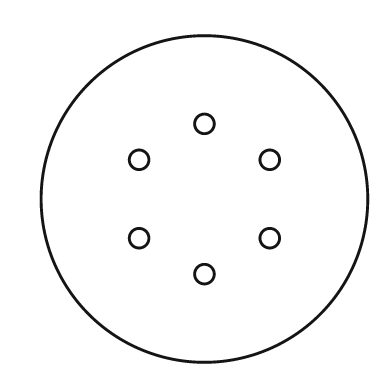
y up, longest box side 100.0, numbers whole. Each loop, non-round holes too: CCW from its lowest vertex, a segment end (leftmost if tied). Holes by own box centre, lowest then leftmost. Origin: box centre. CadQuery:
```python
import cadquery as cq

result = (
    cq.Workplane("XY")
    .moveTo(0.0, 0.0)
    .circle(50.0)
    .moveTo(0.0, -23.0)
    .circle(3.0)
    .moveTo(-20.0, -12.0)
    .circle(3.0)
    .moveTo(20.0, -12.0)
    .circle(3.0)
    .moveTo(-20.0, 12.0)
    .circle(3.0)
    .moveTo(20.0, 12.0)
    .circle(3.0)
    .moveTo(0.0, 23.0)
    .circle(3.0)
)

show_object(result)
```